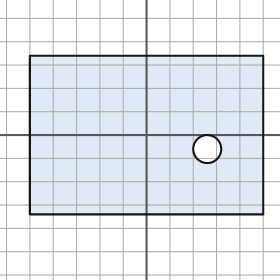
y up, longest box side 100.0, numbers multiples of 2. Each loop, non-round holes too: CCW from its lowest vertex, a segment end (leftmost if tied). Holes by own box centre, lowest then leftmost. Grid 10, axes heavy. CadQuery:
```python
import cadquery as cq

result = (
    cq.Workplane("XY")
    .moveTo(-50.0, -34.0)
    .lineTo(50.0, -34.0)
    .lineTo(50.0, 34.0)
    .lineTo(-50.0, 34.0)
    .close()
    .moveTo(26.0, -6.0)
    .circle(6.0)
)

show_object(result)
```